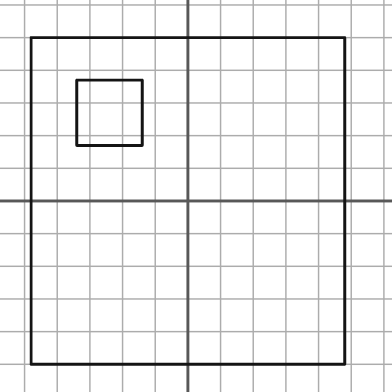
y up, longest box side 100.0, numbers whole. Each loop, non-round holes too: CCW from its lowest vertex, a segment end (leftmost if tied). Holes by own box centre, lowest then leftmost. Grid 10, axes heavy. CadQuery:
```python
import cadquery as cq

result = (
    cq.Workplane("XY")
    .moveTo(-48.0, -50.0)
    .lineTo(48.0, -50.0)
    .lineTo(48.0, 50.0)
    .lineTo(-48.0, 50.0)
    .close()
    .moveTo(-34.0, 17.0)
    .lineTo(-14.0, 17.0)
    .lineTo(-14.0, 37.0)
    .lineTo(-34.0, 37.0)
    .close()
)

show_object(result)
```